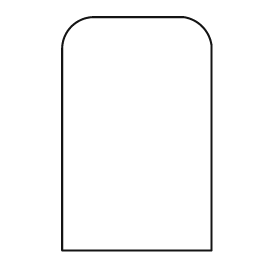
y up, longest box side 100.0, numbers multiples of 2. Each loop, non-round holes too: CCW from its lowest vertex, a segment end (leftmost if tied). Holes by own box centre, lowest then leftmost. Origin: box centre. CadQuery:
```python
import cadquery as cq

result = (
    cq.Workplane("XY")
    .moveTo(-32.0, -50.0)
    .lineTo(32.0, -50.0)
    .lineTo(32.0, 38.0)
    .threePointArc((28.0, 46.0), (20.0, 50.0))
    .lineTo(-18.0, 50.0)
    .threePointArc((-28.0, 46.0), (-32.0, 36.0))
    .close()
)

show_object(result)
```